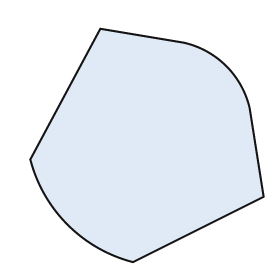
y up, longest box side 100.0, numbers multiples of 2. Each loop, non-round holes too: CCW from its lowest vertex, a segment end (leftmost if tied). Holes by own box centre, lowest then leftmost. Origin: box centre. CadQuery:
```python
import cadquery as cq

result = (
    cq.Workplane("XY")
    .moveTo(-6.0, -50.0)
    .lineTo(50.0, -22.0)
    .lineTo(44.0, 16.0)
    .threePointArc((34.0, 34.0), (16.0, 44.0))
    .lineTo(-20.0, 50.0)
    .lineTo(-50.0, -6.0)
    .threePointArc((-34.0, -34.0), (-6.0, -50.0))
    .close()
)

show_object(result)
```